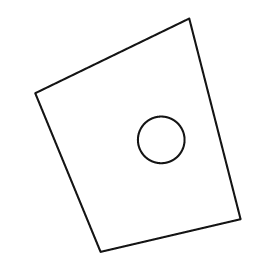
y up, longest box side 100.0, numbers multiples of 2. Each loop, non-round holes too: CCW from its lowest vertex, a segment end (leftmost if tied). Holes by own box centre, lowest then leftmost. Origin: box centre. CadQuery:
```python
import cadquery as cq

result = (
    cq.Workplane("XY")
    .moveTo(-16.0, -50.0)
    .lineTo(44.0, -36.0)
    .lineTo(22.0, 50.0)
    .lineTo(-44.0, 18.0)
    .close()
    .moveTo(10.0, -2.0)
    .circle(10.0)
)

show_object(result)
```